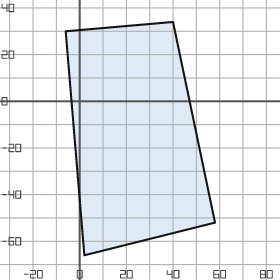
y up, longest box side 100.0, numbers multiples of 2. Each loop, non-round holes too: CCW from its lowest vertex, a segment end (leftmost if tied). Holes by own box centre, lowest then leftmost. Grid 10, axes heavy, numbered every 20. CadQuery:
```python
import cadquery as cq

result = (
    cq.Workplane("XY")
    .moveTo(2.0, -66.0)
    .lineTo(58.0, -52.0)
    .lineTo(40.0, 34.0)
    .lineTo(-6.0, 30.0)
    .close()
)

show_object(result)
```